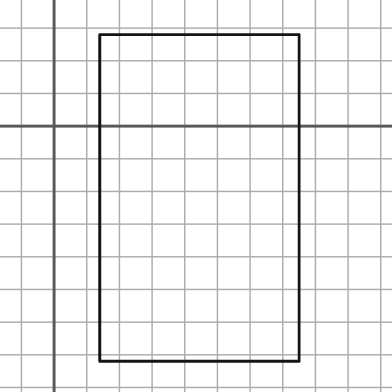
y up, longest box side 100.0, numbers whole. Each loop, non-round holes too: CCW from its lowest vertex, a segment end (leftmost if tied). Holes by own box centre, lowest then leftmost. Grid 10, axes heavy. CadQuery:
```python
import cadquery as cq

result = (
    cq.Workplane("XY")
    .moveTo(14.0, -72.0)
    .lineTo(75.0, -72.0)
    .lineTo(75.0, 28.0)
    .lineTo(14.0, 28.0)
    .close()
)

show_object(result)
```